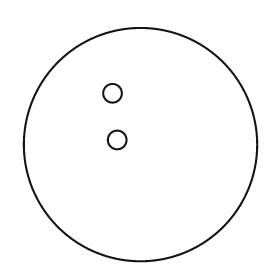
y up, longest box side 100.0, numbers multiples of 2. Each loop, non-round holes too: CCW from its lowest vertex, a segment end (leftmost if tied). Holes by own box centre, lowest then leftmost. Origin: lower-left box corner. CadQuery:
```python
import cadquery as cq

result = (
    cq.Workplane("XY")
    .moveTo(50.0, 50.0)
    .circle(50.0)
    .moveTo(40.0, 52.0)
    .circle(4.0)
    .moveTo(38.0, 72.0)
    .circle(4.0)
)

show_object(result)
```